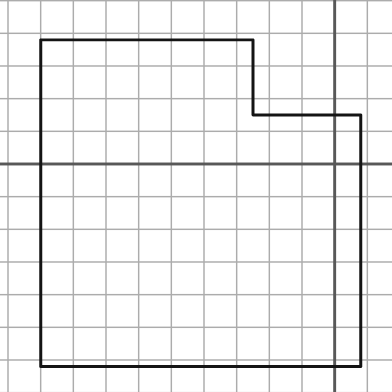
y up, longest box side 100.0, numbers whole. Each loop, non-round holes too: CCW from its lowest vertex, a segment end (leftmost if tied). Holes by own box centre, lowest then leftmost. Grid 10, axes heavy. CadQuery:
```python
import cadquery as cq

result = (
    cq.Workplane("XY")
    .moveTo(-90.0, -62.0)
    .lineTo(8.0, -62.0)
    .lineTo(8.0, 15.0)
    .lineTo(-25.0, 15.0)
    .lineTo(-25.0, 38.0)
    .lineTo(-90.0, 38.0)
    .close()
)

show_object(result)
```